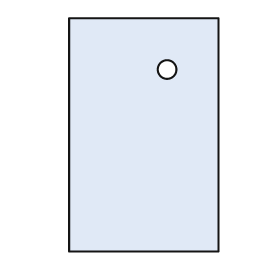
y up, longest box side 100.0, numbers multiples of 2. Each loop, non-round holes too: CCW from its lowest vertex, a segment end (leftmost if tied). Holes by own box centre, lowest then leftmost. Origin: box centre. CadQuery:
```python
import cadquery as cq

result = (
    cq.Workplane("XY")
    .moveTo(-32.0, -50.0)
    .lineTo(32.0, -50.0)
    .lineTo(32.0, 50.0)
    .lineTo(-32.0, 50.0)
    .close()
    .moveTo(10.0, 28.0)
    .circle(4.0)
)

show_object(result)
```